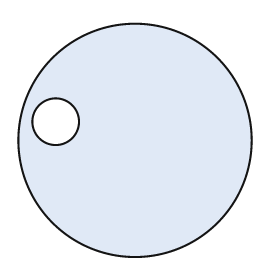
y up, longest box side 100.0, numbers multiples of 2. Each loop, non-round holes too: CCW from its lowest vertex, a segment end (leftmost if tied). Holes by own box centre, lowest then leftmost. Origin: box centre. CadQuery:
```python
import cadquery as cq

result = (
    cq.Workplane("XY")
    .moveTo(0.0, 0.0)
    .circle(50.0)
    .moveTo(-34.0, 8.0)
    .circle(10.0)
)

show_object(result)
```